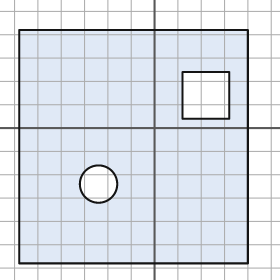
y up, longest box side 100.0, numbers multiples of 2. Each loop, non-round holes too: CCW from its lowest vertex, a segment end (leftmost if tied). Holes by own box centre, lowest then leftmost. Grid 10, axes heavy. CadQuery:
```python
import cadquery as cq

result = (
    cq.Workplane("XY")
    .moveTo(-58.0, -58.0)
    .lineTo(40.0, -58.0)
    .lineTo(40.0, 42.0)
    .lineTo(-58.0, 42.0)
    .close()
    .moveTo(-24.0, -24.0)
    .circle(8.0)
    .moveTo(12.0, 4.0)
    .lineTo(32.0, 4.0)
    .lineTo(32.0, 24.0)
    .lineTo(12.0, 24.0)
    .close()
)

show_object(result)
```